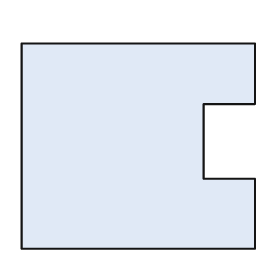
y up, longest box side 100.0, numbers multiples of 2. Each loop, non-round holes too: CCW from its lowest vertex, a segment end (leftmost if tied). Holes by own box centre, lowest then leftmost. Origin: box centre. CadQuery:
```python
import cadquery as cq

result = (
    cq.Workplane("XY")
    .moveTo(-50.0, -44.0)
    .lineTo(50.0, -44.0)
    .lineTo(50.0, -14.0)
    .lineTo(28.0, -14.0)
    .lineTo(28.0, 18.0)
    .lineTo(50.0, 18.0)
    .lineTo(50.0, 44.0)
    .lineTo(-50.0, 44.0)
    .close()
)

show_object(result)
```